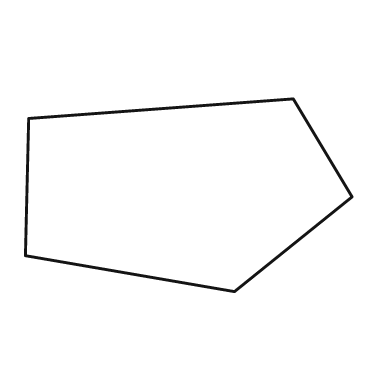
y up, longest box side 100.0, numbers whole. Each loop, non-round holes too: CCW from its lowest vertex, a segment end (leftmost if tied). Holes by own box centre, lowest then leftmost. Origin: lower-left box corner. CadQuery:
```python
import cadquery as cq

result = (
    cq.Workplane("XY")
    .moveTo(64.0, 0.0)
    .lineTo(100.0, 29.0)
    .lineTo(82.0, 59.0)
    .lineTo(1.0, 53.0)
    .lineTo(0.0, 11.0)
    .close()
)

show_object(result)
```